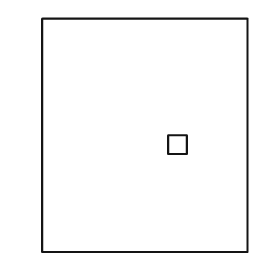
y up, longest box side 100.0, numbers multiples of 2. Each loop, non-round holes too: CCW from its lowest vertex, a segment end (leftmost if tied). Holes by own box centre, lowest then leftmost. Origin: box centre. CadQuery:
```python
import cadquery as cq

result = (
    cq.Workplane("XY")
    .moveTo(-44.0, -50.0)
    .lineTo(44.0, -50.0)
    .lineTo(44.0, 50.0)
    .lineTo(-44.0, 50.0)
    .close()
    .moveTo(10.0, -8.0)
    .lineTo(18.0, -8.0)
    .lineTo(18.0, 0.0)
    .lineTo(10.0, 0.0)
    .close()
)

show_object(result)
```